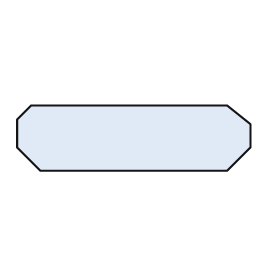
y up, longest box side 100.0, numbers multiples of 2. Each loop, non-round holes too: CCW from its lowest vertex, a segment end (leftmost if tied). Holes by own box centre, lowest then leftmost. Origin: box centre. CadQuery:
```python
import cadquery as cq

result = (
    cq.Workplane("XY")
    .moveTo(-40.0, -14.0)
    .lineTo(40.0, -14.0)
    .lineTo(50.0, -4.0)
    .lineTo(50.0, 6.0)
    .lineTo(40.0, 14.0)
    .lineTo(-44.0, 14.0)
    .lineTo(-50.0, 8.0)
    .lineTo(-50.0, -4.0)
    .close()
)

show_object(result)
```